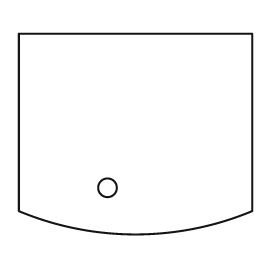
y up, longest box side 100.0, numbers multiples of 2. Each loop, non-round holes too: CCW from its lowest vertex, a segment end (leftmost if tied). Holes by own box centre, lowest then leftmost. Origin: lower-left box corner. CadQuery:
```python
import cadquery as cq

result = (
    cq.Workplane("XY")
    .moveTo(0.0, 10.0)
    .threePointArc((50.0, 0.0), (100.0, 10.0))
    .lineTo(100.0, 86.0)
    .lineTo(0.0, 86.0)
    .close()
    .moveTo(38.0, 20.0)
    .circle(4.0)
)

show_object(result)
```